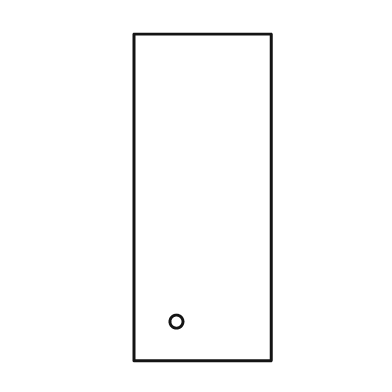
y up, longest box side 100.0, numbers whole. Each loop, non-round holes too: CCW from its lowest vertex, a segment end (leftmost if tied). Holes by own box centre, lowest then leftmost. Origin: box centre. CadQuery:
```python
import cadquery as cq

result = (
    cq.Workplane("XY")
    .moveTo(-21.0, -50.0)
    .lineTo(21.0, -50.0)
    .lineTo(21.0, 50.0)
    .lineTo(-21.0, 50.0)
    .close()
    .moveTo(-8.0, -38.0)
    .circle(2.0)
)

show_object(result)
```